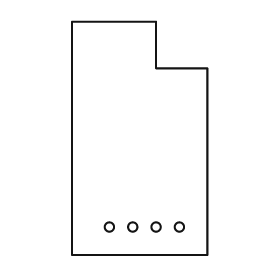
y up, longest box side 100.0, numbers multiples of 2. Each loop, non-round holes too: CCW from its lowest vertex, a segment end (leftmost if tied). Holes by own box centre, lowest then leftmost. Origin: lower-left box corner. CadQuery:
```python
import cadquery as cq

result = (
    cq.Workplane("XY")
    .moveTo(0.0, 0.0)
    .lineTo(58.0, 0.0)
    .lineTo(58.0, 80.0)
    .lineTo(36.0, 80.0)
    .lineTo(36.0, 100.0)
    .lineTo(0.0, 100.0)
    .close()
    .moveTo(16.0, 12.0)
    .circle(2.0)
    .moveTo(26.0, 12.0)
    .circle(2.0)
    .moveTo(36.0, 12.0)
    .circle(2.0)
    .moveTo(46.0, 12.0)
    .circle(2.0)
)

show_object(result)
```